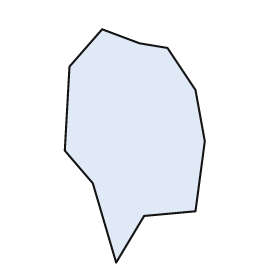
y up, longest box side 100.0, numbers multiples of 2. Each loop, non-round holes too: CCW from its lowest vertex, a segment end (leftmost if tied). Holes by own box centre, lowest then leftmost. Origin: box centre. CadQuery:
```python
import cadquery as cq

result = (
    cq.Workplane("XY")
    .moveTo(-8.0, -50.0)
    .lineTo(4.0, -30.0)
    .lineTo(26.0, -28.0)
    .lineTo(30.0, 2.0)
    .lineTo(26.0, 24.0)
    .lineTo(14.0, 42.0)
    .lineTo(2.0, 44.0)
    .lineTo(-14.0, 50.0)
    .lineTo(-28.0, 34.0)
    .lineTo(-30.0, -2.0)
    .lineTo(-18.0, -16.0)
    .close()
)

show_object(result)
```